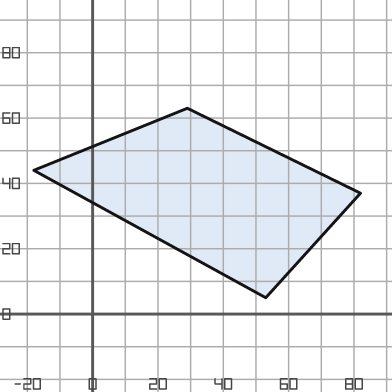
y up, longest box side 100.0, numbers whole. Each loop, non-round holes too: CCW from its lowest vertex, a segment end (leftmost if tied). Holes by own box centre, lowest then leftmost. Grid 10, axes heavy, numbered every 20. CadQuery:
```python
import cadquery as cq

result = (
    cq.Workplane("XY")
    .moveTo(53.0, 5.0)
    .lineTo(82.0, 37.0)
    .lineTo(29.0, 63.0)
    .lineTo(-18.0, 44.0)
    .close()
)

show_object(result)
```